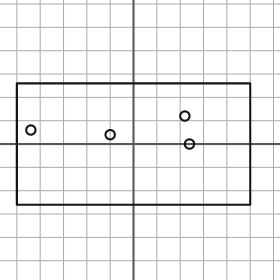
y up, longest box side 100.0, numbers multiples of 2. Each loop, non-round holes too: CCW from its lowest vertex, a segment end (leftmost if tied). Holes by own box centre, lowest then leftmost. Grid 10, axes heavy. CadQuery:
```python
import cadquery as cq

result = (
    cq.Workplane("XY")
    .moveTo(-50.0, -26.0)
    .lineTo(50.0, -26.0)
    .lineTo(50.0, 26.0)
    .lineTo(-50.0, 26.0)
    .close()
    .moveTo(24.0, 0.0)
    .circle(2.0)
    .moveTo(-10.0, 4.0)
    .circle(2.0)
    .moveTo(-44.0, 6.0)
    .circle(2.0)
    .moveTo(22.0, 12.0)
    .circle(2.0)
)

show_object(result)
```